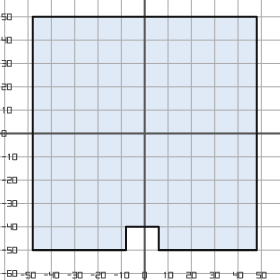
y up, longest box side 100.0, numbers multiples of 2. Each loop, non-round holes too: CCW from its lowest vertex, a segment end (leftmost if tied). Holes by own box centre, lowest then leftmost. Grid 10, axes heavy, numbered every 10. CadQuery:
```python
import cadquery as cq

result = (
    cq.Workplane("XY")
    .moveTo(-48.0, -50.0)
    .lineTo(-8.0, -50.0)
    .lineTo(-8.0, -40.0)
    .lineTo(6.0, -40.0)
    .lineTo(6.0, -50.0)
    .lineTo(48.0, -50.0)
    .lineTo(48.0, 50.0)
    .lineTo(-48.0, 50.0)
    .close()
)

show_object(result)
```